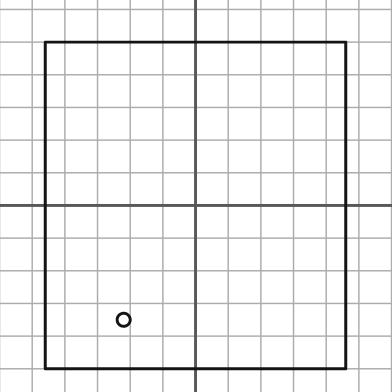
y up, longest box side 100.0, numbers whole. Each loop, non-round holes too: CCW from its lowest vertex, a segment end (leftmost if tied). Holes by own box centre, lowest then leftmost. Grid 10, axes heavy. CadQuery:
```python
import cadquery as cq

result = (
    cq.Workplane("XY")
    .moveTo(-46.0, -50.0)
    .lineTo(46.0, -50.0)
    .lineTo(46.0, 50.0)
    .lineTo(-46.0, 50.0)
    .close()
    .moveTo(-22.0, -35.0)
    .circle(2.0)
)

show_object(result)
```